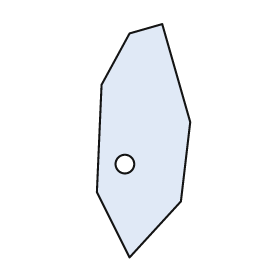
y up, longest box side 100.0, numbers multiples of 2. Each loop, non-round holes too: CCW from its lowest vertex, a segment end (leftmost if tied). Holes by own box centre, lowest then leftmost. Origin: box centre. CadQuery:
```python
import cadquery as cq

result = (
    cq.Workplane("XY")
    .moveTo(-6.0, -50.0)
    .lineTo(16.0, -26.0)
    .lineTo(20.0, 8.0)
    .lineTo(8.0, 50.0)
    .lineTo(-6.0, 46.0)
    .lineTo(-18.0, 24.0)
    .lineTo(-20.0, -22.0)
    .close()
    .moveTo(-8.0, -10.0)
    .circle(4.0)
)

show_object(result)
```